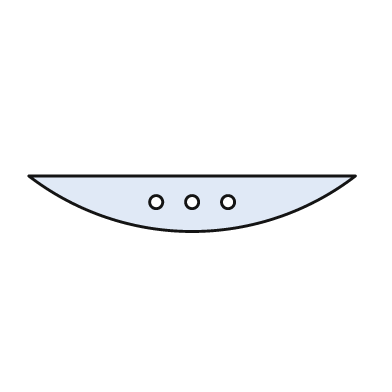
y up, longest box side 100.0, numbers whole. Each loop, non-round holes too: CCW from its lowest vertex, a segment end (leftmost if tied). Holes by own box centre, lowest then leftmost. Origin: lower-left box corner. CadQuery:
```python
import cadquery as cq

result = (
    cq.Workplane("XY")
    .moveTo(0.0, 17.0)
    .threePointArc((50.0, 0.0), (100.0, 17.0))
    .close()
    .moveTo(39.0, 9.0)
    .circle(2.0)
    .moveTo(50.0, 9.0)
    .circle(2.0)
    .moveTo(61.0, 9.0)
    .circle(2.0)
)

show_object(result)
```